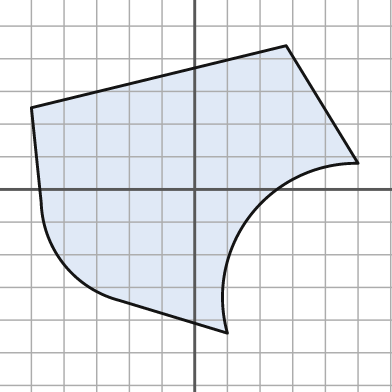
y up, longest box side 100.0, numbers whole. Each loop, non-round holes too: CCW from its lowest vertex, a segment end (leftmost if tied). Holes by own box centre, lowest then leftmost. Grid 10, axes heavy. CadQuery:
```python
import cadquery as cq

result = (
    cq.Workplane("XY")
    .moveTo(10.0, -44.0)
    .threePointArc((17.0, -8.0), (50.0, 8.0))
    .lineTo(28.0, 44.0)
    .lineTo(-50.0, 25.0)
    .lineTo(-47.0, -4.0)
    .threePointArc((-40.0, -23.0), (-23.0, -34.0))
    .close()
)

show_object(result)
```